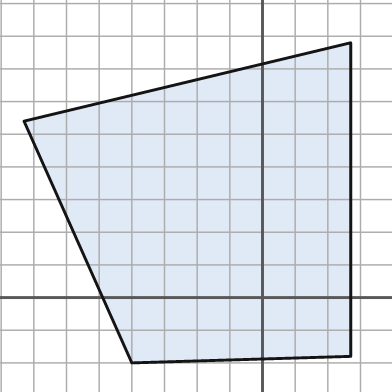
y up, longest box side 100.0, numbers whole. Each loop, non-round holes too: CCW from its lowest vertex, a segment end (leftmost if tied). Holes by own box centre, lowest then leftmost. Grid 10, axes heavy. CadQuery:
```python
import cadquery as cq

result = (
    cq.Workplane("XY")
    .moveTo(-40.0, -20.0)
    .lineTo(27.0, -18.0)
    .lineTo(27.0, 78.0)
    .lineTo(-73.0, 54.0)
    .close()
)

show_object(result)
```